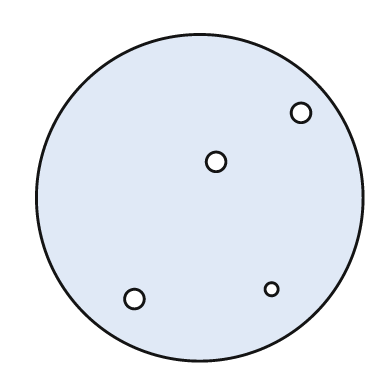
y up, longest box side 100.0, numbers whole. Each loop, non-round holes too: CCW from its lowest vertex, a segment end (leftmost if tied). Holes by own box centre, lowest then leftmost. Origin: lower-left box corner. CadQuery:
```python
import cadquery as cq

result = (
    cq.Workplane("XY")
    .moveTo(50.0, 50.0)
    .circle(50.0)
    .moveTo(30.0, 19.0)
    .circle(3.0)
    .moveTo(72.0, 22.0)
    .circle(2.0)
    .moveTo(55.0, 61.0)
    .circle(3.0)
    .moveTo(81.0, 76.0)
    .circle(3.0)
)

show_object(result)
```